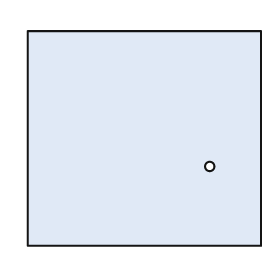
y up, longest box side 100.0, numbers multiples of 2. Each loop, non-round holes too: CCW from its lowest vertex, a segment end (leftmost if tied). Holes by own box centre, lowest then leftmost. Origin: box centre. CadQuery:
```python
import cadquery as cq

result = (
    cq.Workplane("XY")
    .moveTo(-50.0, -46.0)
    .lineTo(50.0, -46.0)
    .lineTo(50.0, 46.0)
    .lineTo(-50.0, 46.0)
    .close()
    .moveTo(28.0, -12.0)
    .circle(2.0)
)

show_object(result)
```